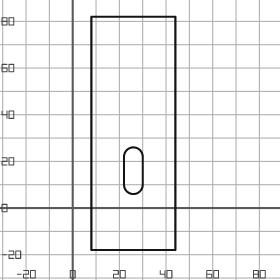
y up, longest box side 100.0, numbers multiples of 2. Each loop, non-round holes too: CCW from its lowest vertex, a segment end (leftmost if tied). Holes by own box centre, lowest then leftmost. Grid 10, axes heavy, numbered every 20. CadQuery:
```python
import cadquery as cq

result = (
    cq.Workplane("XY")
    .moveTo(8.0, -18.0)
    .lineTo(44.0, -18.0)
    .lineTo(44.0, 82.0)
    .lineTo(8.0, 82.0)
    .close()
    .moveTo(22.0, 10.0)
    .threePointArc((26.0, 6.0), (30.0, 10.0))
    .lineTo(30.0, 22.0)
    .threePointArc((26.0, 26.0), (22.0, 22.0))
    .close()
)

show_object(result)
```